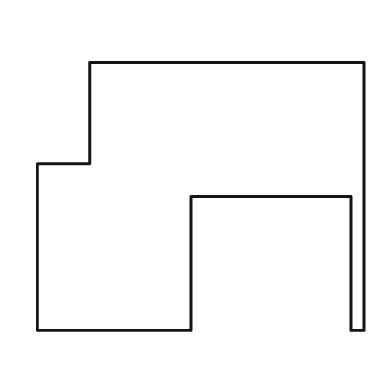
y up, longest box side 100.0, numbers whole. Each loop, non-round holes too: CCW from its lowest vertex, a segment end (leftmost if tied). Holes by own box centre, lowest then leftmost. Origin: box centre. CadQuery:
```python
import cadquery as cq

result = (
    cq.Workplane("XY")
    .moveTo(-50.0, -41.0)
    .lineTo(-3.0, -41.0)
    .lineTo(-3.0, 0.0)
    .lineTo(46.0, 0.0)
    .lineTo(46.0, -41.0)
    .lineTo(50.0, -41.0)
    .lineTo(50.0, 41.0)
    .lineTo(-34.0, 41.0)
    .lineTo(-34.0, 10.0)
    .lineTo(-50.0, 10.0)
    .close()
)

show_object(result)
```